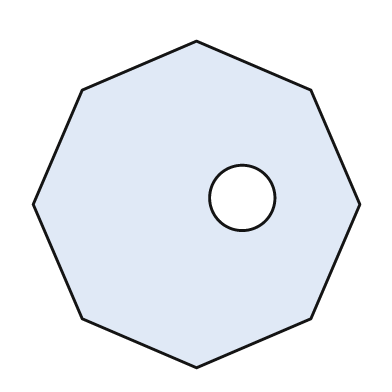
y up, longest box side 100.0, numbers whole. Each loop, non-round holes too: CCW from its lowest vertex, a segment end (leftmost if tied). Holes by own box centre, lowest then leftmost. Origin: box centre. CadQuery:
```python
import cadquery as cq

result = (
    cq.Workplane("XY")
    .moveTo(0.0, -50.0)
    .lineTo(35.0, -35.0)
    .lineTo(50.0, 0.0)
    .lineTo(35.0, 35.0)
    .lineTo(0.0, 50.0)
    .lineTo(-35.0, 35.0)
    .lineTo(-50.0, 0.0)
    .lineTo(-35.0, -35.0)
    .close()
    .moveTo(14.0, 2.0)
    .circle(10.0)
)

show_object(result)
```